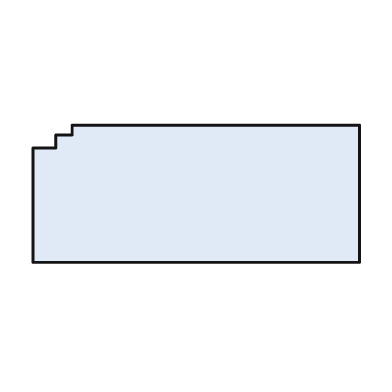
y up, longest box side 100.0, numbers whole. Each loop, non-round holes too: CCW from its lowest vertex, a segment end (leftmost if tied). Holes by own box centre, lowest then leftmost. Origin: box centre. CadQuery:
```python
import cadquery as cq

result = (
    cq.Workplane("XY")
    .moveTo(-50.0, -21.0)
    .lineTo(50.0, -21.0)
    .lineTo(50.0, 21.0)
    .lineTo(-38.0, 21.0)
    .lineTo(-38.0, 18.0)
    .lineTo(-43.0, 18.0)
    .lineTo(-43.0, 14.0)
    .lineTo(-50.0, 14.0)
    .close()
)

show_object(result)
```